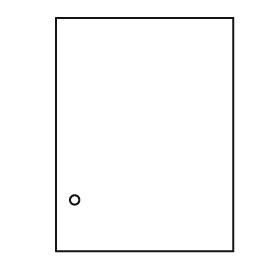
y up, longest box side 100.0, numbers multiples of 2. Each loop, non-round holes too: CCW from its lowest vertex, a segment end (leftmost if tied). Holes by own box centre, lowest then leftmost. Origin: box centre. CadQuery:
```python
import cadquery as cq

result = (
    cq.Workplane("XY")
    .moveTo(-38.0, -50.0)
    .lineTo(38.0, -50.0)
    .lineTo(38.0, 50.0)
    .lineTo(-38.0, 50.0)
    .close()
    .moveTo(-30.0, -28.0)
    .circle(2.0)
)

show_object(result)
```